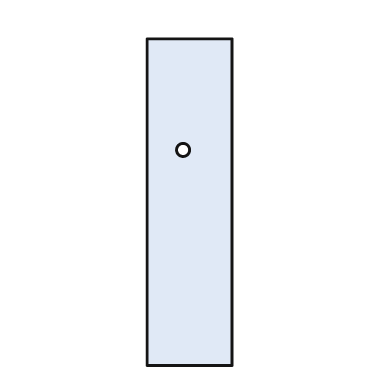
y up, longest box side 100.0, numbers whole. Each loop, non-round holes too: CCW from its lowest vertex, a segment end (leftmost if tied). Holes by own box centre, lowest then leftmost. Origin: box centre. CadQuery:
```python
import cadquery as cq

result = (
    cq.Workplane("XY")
    .moveTo(-13.0, -50.0)
    .lineTo(13.0, -50.0)
    .lineTo(13.0, 50.0)
    .lineTo(-13.0, 50.0)
    .close()
    .moveTo(-2.0, 16.0)
    .circle(2.0)
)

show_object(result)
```